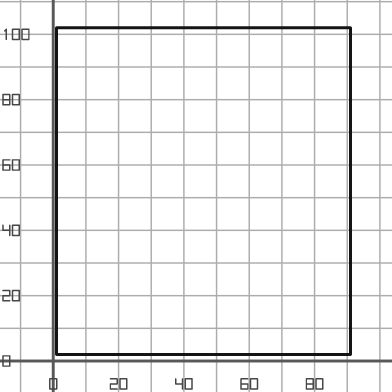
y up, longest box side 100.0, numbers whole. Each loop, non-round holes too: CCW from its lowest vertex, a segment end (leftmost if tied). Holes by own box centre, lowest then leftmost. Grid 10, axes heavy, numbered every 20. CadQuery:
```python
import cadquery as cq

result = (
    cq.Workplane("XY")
    .moveTo(1.0, 2.0)
    .lineTo(91.0, 2.0)
    .lineTo(91.0, 102.0)
    .lineTo(1.0, 102.0)
    .close()
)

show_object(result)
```